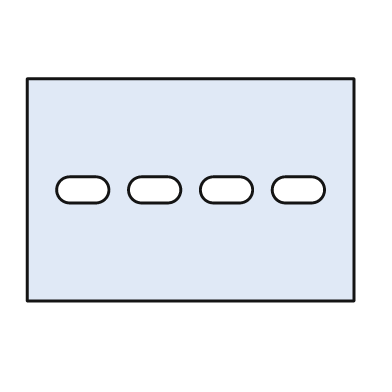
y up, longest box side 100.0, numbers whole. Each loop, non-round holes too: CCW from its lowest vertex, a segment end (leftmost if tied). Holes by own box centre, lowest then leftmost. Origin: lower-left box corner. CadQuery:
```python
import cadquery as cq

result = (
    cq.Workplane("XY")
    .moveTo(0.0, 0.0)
    .lineTo(100.0, 0.0)
    .lineTo(100.0, 68.0)
    .lineTo(0.0, 68.0)
    .close()
    .moveTo(13.0, 30.0)
    .lineTo(21.0, 30.0)
    .threePointArc((25.0, 34.0), (21.0, 38.0))
    .lineTo(13.0, 38.0)
    .threePointArc((9.0, 34.0), (13.0, 30.0))
    .close()
    .moveTo(35.0, 30.0)
    .lineTo(43.0, 30.0)
    .threePointArc((47.0, 34.0), (43.0, 38.0))
    .lineTo(35.0, 38.0)
    .threePointArc((31.0, 34.0), (35.0, 30.0))
    .close()
    .moveTo(57.0, 30.0)
    .lineTo(65.0, 30.0)
    .threePointArc((69.0, 34.0), (65.0, 38.0))
    .lineTo(57.0, 38.0)
    .threePointArc((53.0, 34.0), (57.0, 30.0))
    .close()
    .moveTo(79.0, 30.0)
    .lineTo(87.0, 30.0)
    .threePointArc((91.0, 34.0), (87.0, 38.0))
    .lineTo(79.0, 38.0)
    .threePointArc((75.0, 34.0), (79.0, 30.0))
    .close()
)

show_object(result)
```